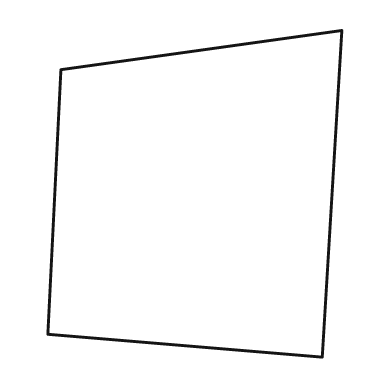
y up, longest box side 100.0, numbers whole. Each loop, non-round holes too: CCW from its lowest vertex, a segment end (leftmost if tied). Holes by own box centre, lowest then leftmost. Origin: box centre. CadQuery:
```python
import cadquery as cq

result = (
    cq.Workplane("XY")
    .moveTo(39.0, -50.0)
    .lineTo(45.0, 50.0)
    .lineTo(-41.0, 38.0)
    .lineTo(-45.0, -43.0)
    .close()
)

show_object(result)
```